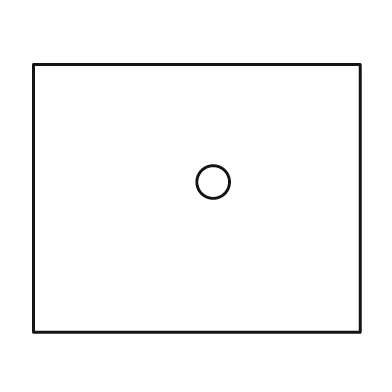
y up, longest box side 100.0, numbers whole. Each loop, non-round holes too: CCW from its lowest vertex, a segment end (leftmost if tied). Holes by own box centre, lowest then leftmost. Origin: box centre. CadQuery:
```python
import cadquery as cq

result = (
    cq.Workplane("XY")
    .moveTo(-50.0, -41.0)
    .lineTo(50.0, -41.0)
    .lineTo(50.0, 41.0)
    .lineTo(-50.0, 41.0)
    .close()
    .moveTo(5.0, 5.0)
    .circle(5.0)
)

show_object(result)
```